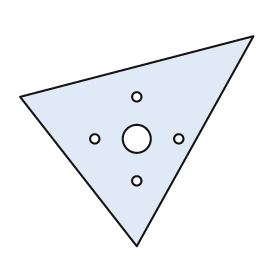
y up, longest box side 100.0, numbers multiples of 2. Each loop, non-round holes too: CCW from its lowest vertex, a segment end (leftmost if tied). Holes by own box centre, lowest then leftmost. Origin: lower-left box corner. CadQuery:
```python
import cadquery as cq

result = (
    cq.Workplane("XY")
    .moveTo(50.0, 0.0)
    .lineTo(100.0, 90.0)
    .lineTo(0.0, 64.0)
    .close()
    .moveTo(50.0, 28.0)
    .circle(2.0)
    .moveTo(32.0, 46.0)
    .circle(2.0)
    .moveTo(50.0, 46.0)
    .circle(6.0)
    .moveTo(68.0, 46.0)
    .circle(2.0)
    .moveTo(50.0, 64.0)
    .circle(2.0)
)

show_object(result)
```